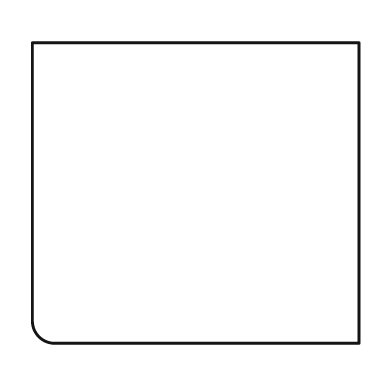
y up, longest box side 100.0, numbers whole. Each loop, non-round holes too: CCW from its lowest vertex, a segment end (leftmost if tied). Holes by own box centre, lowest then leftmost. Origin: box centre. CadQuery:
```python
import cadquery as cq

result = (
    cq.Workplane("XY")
    .moveTo(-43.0, -46.0)
    .lineTo(50.0, -46.0)
    .lineTo(50.0, 46.0)
    .lineTo(-50.0, 46.0)
    .lineTo(-50.0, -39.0)
    .threePointArc((-48.0, -44.0), (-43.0, -46.0))
    .close()
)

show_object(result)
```